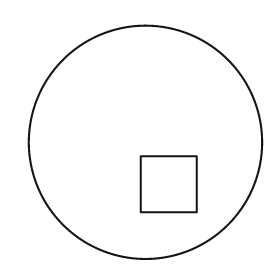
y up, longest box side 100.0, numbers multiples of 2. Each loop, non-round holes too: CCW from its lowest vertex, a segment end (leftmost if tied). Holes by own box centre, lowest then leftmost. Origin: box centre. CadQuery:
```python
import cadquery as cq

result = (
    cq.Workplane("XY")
    .moveTo(0.0, 0.0)
    .circle(50.0)
    .moveTo(-2.0, -30.0)
    .lineTo(22.0, -30.0)
    .lineTo(22.0, -6.0)
    .lineTo(-2.0, -6.0)
    .close()
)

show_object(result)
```